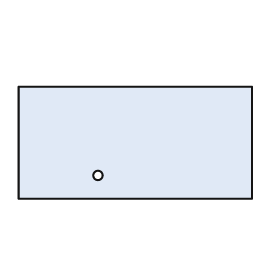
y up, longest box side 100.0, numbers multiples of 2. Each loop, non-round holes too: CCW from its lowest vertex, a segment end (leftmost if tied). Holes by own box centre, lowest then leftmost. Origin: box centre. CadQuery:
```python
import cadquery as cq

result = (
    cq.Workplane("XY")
    .moveTo(-50.0, -24.0)
    .lineTo(50.0, -24.0)
    .lineTo(50.0, 24.0)
    .lineTo(-50.0, 24.0)
    .close()
    .moveTo(-16.0, -14.0)
    .circle(2.0)
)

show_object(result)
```